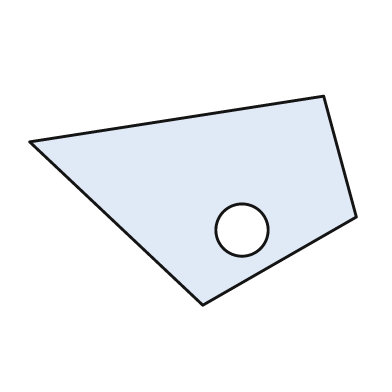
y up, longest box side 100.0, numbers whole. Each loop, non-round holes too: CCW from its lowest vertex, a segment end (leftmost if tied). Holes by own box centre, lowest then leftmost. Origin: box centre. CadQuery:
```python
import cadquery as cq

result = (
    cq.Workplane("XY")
    .moveTo(3.0, -32.0)
    .lineTo(50.0, -5.0)
    .lineTo(40.0, 32.0)
    .lineTo(-50.0, 18.0)
    .close()
    .moveTo(15.0, -9.0)
    .circle(8.0)
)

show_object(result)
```